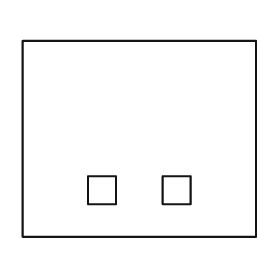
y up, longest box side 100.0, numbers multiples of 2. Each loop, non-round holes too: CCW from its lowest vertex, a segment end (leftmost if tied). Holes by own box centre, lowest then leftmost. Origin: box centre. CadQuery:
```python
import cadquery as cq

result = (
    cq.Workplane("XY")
    .moveTo(-50.0, -42.0)
    .lineTo(50.0, -42.0)
    .lineTo(50.0, 42.0)
    .lineTo(-50.0, 42.0)
    .close()
    .moveTo(-22.0, -28.0)
    .lineTo(-10.0, -28.0)
    .lineTo(-10.0, -16.0)
    .lineTo(-22.0, -16.0)
    .close()
    .moveTo(10.0, -28.0)
    .lineTo(22.0, -28.0)
    .lineTo(22.0, -16.0)
    .lineTo(10.0, -16.0)
    .close()
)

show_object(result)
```